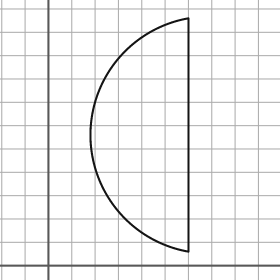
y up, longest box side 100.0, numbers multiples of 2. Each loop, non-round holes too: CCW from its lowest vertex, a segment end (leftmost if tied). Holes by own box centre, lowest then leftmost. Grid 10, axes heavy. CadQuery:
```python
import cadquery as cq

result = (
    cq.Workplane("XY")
    .moveTo(60.0, 6.0)
    .lineTo(60.0, 106.0)
    .threePointArc((18.0, 56.0), (60.0, 6.0))
    .close()
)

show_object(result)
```